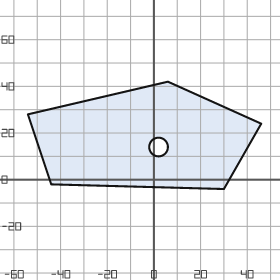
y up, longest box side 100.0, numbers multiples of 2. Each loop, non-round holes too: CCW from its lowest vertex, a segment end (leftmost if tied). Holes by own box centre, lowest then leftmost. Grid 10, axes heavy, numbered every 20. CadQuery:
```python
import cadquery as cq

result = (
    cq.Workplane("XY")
    .moveTo(30.0, -4.0)
    .lineTo(46.0, 24.0)
    .lineTo(6.0, 42.0)
    .lineTo(-54.0, 28.0)
    .lineTo(-44.0, -2.0)
    .close()
    .moveTo(2.0, 14.0)
    .circle(4.0)
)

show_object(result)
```